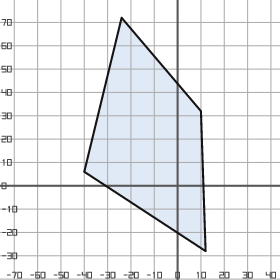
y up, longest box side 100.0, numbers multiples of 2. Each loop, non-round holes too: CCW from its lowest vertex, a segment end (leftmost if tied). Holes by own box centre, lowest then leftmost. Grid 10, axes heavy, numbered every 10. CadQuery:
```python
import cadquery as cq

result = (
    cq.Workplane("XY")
    .moveTo(12.0, -28.0)
    .lineTo(10.0, 32.0)
    .lineTo(-24.0, 72.0)
    .lineTo(-40.0, 6.0)
    .close()
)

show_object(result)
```